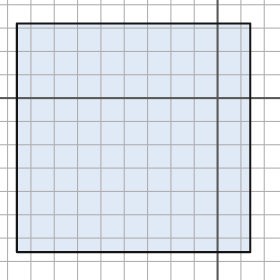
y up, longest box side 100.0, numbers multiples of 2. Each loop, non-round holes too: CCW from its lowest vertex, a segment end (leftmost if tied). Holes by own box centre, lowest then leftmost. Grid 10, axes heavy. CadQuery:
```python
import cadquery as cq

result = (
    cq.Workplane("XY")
    .moveTo(-86.0, -66.0)
    .lineTo(14.0, -66.0)
    .lineTo(14.0, 32.0)
    .lineTo(-86.0, 32.0)
    .close()
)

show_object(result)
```